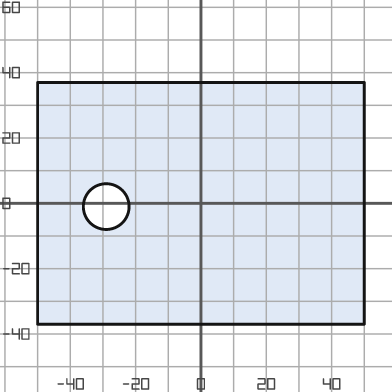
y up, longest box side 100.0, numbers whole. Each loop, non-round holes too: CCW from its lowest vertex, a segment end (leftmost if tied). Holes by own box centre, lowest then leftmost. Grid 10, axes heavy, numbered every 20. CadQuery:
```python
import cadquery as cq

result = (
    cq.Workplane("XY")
    .moveTo(-50.0, -37.0)
    .lineTo(50.0, -37.0)
    .lineTo(50.0, 37.0)
    .lineTo(-50.0, 37.0)
    .close()
    .moveTo(-29.0, -1.0)
    .circle(7.0)
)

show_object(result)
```